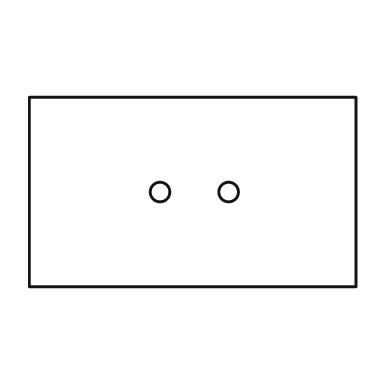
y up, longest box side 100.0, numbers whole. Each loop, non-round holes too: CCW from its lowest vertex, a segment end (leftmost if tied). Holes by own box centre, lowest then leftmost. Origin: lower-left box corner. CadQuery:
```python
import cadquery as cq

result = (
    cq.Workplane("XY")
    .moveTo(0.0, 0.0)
    .lineTo(100.0, 0.0)
    .lineTo(100.0, 58.0)
    .lineTo(0.0, 58.0)
    .close()
    .moveTo(40.0, 29.0)
    .circle(3.0)
    .moveTo(61.0, 29.0)
    .circle(3.0)
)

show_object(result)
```